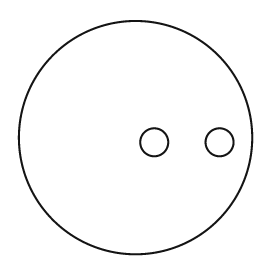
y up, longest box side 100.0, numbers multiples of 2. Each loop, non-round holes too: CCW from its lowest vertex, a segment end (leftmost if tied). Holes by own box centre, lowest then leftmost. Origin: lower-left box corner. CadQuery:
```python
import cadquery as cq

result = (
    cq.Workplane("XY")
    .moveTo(50.0, 50.0)
    .circle(50.0)
    .moveTo(58.0, 48.0)
    .circle(6.0)
    .moveTo(86.0, 48.0)
    .circle(6.0)
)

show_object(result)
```